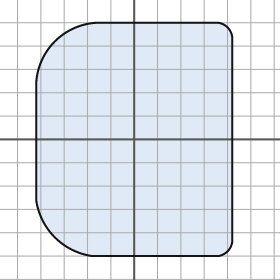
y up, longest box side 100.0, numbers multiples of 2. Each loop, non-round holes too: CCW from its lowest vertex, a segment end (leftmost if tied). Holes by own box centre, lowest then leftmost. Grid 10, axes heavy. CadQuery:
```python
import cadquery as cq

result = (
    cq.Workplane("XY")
    .moveTo(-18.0, -50.0)
    .lineTo(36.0, -50.0)
    .threePointArc((40.0, -48.0), (42.0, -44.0))
    .lineTo(42.0, 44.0)
    .threePointArc((40.0, 48.0), (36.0, 50.0))
    .lineTo(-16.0, 50.0)
    .threePointArc((-34.0, 42.0), (-42.0, 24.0))
    .lineTo(-42.0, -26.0)
    .threePointArc((-34.0, -42.0), (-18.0, -50.0))
    .close()
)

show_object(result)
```